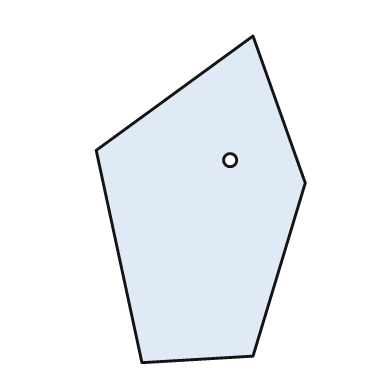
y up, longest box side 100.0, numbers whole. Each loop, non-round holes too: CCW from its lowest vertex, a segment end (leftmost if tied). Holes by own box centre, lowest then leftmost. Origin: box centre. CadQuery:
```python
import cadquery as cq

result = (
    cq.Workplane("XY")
    .moveTo(-18.0, -50.0)
    .lineTo(16.0, -48.0)
    .lineTo(32.0, 5.0)
    .lineTo(16.0, 50.0)
    .lineTo(-32.0, 15.0)
    .close()
    .moveTo(9.0, 12.0)
    .circle(2.0)
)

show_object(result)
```